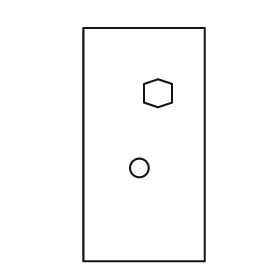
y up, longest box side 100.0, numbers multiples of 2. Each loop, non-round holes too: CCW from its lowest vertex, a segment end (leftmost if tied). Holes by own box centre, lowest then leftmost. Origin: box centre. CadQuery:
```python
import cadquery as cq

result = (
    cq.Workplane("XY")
    .moveTo(-26.0, -50.0)
    .lineTo(26.0, -50.0)
    .lineTo(26.0, 50.0)
    .lineTo(-26.0, 50.0)
    .close()
    .moveTo(-2.0, -10.0)
    .circle(4.0)
    .moveTo(6.0, 16.0)
    .lineTo(12.0, 18.0)
    .lineTo(12.0, 26.0)
    .lineTo(6.0, 28.0)
    .lineTo(0.0, 26.0)
    .lineTo(0.0, 18.0)
    .close()
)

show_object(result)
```